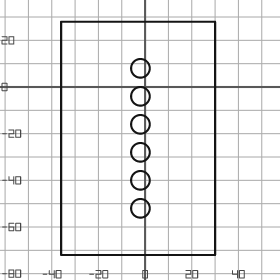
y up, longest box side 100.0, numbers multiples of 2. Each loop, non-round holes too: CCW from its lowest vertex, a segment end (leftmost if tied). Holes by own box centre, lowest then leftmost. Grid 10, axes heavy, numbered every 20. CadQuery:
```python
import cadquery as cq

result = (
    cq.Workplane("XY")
    .moveTo(-36.0, -72.0)
    .lineTo(30.0, -72.0)
    .lineTo(30.0, 28.0)
    .lineTo(-36.0, 28.0)
    .close()
    .moveTo(-2.0, -52.0)
    .circle(4.0)
    .moveTo(-2.0, -40.0)
    .circle(4.0)
    .moveTo(-2.0, -28.0)
    .circle(4.0)
    .moveTo(-2.0, -16.0)
    .circle(4.0)
    .moveTo(-2.0, -4.0)
    .circle(4.0)
    .moveTo(-2.0, 8.0)
    .circle(4.0)
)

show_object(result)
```